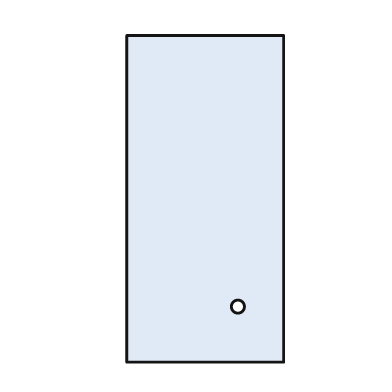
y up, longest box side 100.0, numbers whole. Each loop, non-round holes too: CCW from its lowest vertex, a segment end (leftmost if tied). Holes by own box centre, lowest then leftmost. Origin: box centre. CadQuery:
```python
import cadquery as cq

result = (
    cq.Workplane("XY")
    .moveTo(-24.0, -50.0)
    .lineTo(24.0, -50.0)
    .lineTo(24.0, 50.0)
    .lineTo(-24.0, 50.0)
    .close()
    .moveTo(10.0, -33.0)
    .circle(2.0)
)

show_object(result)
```